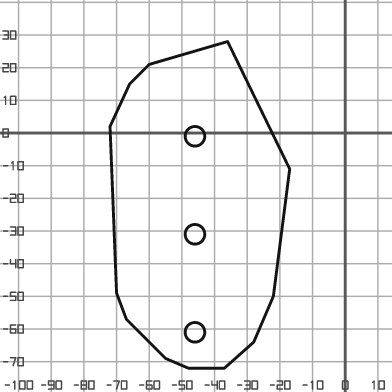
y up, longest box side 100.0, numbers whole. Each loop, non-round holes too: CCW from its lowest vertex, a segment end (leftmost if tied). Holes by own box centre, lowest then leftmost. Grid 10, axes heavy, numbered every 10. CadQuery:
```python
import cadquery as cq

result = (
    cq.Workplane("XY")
    .moveTo(-48.0, -72.0)
    .lineTo(-37.0, -72.0)
    .lineTo(-28.0, -64.0)
    .lineTo(-22.0, -50.0)
    .lineTo(-17.0, -11.0)
    .lineTo(-36.0, 28.0)
    .lineTo(-60.0, 21.0)
    .lineTo(-66.0, 15.0)
    .lineTo(-72.0, 2.0)
    .lineTo(-70.0, -49.0)
    .lineTo(-67.0, -57.0)
    .lineTo(-55.0, -69.0)
    .close()
    .moveTo(-46.0, -61.0)
    .circle(3.0)
    .moveTo(-46.0, -31.0)
    .circle(3.0)
    .moveTo(-46.0, -1.0)
    .circle(3.0)
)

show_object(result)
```